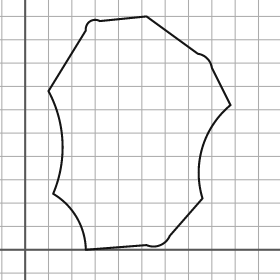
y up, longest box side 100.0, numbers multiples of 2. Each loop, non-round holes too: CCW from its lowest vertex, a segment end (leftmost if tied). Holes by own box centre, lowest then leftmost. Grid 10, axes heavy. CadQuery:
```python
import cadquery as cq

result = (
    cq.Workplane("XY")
    .moveTo(26.0, 0.0)
    .lineTo(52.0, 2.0)
    .threePointArc((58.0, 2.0), (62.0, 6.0))
    .lineTo(76.0, 22.0)
    .threePointArc((76.0, 44.0), (88.0, 62.0))
    .lineTo(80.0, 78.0)
    .threePointArc((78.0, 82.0), (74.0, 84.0))
    .lineTo(52.0, 100.0)
    .lineTo(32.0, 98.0)
    .threePointArc((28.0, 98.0), (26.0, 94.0))
    .lineTo(10.0, 68.0)
    .threePointArc((16.0, 46.0), (12.0, 24.0))
    .threePointArc((22.0, 14.0), (26.0, 0.0))
    .close()
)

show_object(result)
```